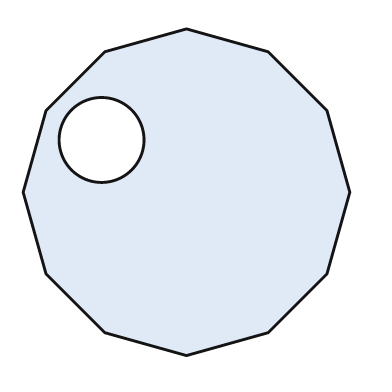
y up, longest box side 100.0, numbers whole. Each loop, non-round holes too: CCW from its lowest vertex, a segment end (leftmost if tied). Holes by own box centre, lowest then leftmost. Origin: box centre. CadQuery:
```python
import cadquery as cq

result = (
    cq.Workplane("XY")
    .moveTo(0.0, -50.0)
    .lineTo(25.0, -43.0)
    .lineTo(43.0, -25.0)
    .lineTo(50.0, 0.0)
    .lineTo(43.0, 25.0)
    .lineTo(25.0, 43.0)
    .lineTo(0.0, 50.0)
    .lineTo(-25.0, 43.0)
    .lineTo(-43.0, 25.0)
    .lineTo(-50.0, 0.0)
    .lineTo(-43.0, -25.0)
    .lineTo(-25.0, -43.0)
    .close()
    .moveTo(-26.0, 16.0)
    .circle(13.0)
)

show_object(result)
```